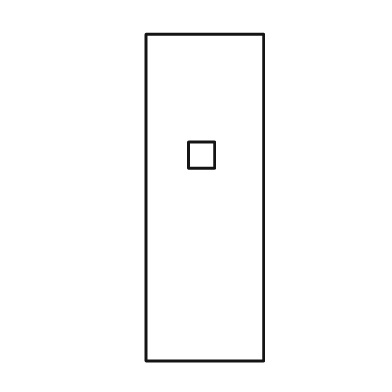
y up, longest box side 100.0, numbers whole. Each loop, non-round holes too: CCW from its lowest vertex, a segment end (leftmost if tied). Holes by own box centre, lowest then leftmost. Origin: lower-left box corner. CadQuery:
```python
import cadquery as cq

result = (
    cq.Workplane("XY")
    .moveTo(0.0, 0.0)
    .lineTo(36.0, 0.0)
    .lineTo(36.0, 100.0)
    .lineTo(0.0, 100.0)
    .close()
    .moveTo(13.0, 59.0)
    .lineTo(21.0, 59.0)
    .lineTo(21.0, 67.0)
    .lineTo(13.0, 67.0)
    .close()
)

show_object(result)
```